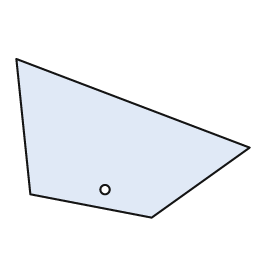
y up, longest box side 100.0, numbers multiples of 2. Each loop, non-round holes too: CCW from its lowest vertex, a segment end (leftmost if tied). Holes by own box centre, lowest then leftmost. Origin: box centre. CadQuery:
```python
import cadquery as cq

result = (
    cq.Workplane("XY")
    .moveTo(8.0, -34.0)
    .lineTo(50.0, -4.0)
    .lineTo(-50.0, 34.0)
    .lineTo(-44.0, -24.0)
    .close()
    .moveTo(-12.0, -22.0)
    .circle(2.0)
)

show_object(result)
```